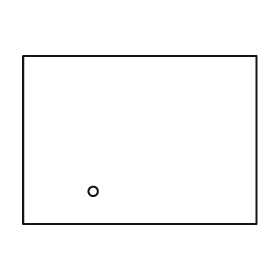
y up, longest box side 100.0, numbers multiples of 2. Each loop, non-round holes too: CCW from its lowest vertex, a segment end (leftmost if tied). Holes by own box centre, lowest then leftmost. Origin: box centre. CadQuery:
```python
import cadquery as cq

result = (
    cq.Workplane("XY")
    .moveTo(-50.0, -36.0)
    .lineTo(50.0, -36.0)
    .lineTo(50.0, 36.0)
    .lineTo(-50.0, 36.0)
    .close()
    .moveTo(-20.0, -22.0)
    .circle(2.0)
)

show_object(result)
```